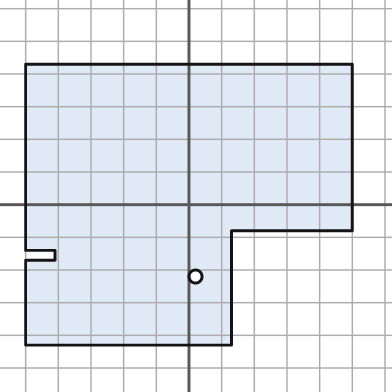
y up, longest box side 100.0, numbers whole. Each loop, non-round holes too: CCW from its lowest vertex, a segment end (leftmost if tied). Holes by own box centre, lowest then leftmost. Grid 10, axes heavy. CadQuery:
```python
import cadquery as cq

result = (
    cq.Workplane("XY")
    .moveTo(-50.0, -43.0)
    .lineTo(13.0, -43.0)
    .lineTo(13.0, -8.0)
    .lineTo(50.0, -8.0)
    .lineTo(50.0, 43.0)
    .lineTo(-50.0, 43.0)
    .lineTo(-50.0, -14.0)
    .lineTo(-41.0, -14.0)
    .lineTo(-41.0, -17.0)
    .lineTo(-50.0, -17.0)
    .close()
    .moveTo(2.0, -22.0)
    .circle(2.0)
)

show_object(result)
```